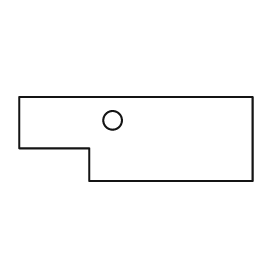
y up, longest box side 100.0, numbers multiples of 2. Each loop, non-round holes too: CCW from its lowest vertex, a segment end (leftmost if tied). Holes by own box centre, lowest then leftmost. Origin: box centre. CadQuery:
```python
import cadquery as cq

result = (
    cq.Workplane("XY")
    .moveTo(-20.0, -18.0)
    .lineTo(50.0, -18.0)
    .lineTo(50.0, 18.0)
    .lineTo(-50.0, 18.0)
    .lineTo(-50.0, -4.0)
    .lineTo(-20.0, -4.0)
    .close()
    .moveTo(-10.0, 8.0)
    .circle(4.0)
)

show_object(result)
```